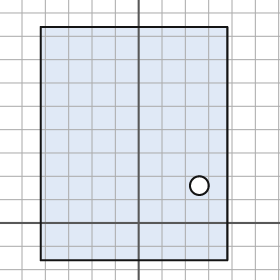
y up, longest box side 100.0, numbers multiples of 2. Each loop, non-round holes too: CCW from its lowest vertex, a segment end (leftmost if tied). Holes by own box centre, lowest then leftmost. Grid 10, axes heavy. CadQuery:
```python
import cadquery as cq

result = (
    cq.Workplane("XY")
    .moveTo(-42.0, -16.0)
    .lineTo(38.0, -16.0)
    .lineTo(38.0, 84.0)
    .lineTo(-42.0, 84.0)
    .close()
    .moveTo(26.0, 16.0)
    .circle(4.0)
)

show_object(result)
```